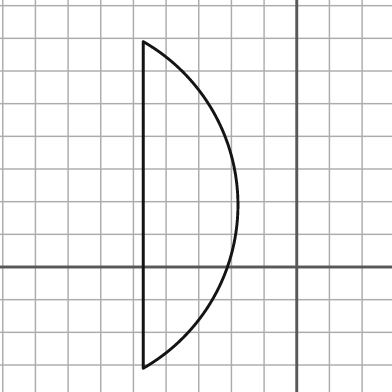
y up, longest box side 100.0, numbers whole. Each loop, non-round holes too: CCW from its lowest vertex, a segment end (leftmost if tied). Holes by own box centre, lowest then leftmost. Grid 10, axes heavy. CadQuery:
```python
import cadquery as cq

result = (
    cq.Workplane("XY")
    .moveTo(-47.0, -31.0)
    .threePointArc((-18.0, 19.0), (-47.0, 69.0))
    .close()
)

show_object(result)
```